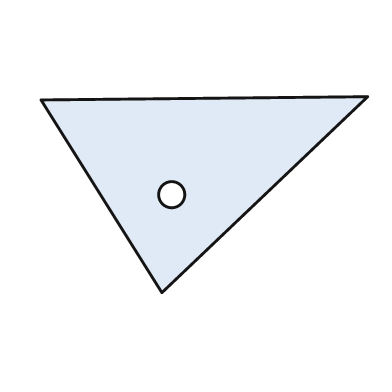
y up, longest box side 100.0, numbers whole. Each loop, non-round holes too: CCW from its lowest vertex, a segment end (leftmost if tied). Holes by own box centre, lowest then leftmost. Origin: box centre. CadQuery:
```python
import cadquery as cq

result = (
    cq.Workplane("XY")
    .moveTo(-13.0, -30.0)
    .lineTo(50.0, 30.0)
    .lineTo(-50.0, 29.0)
    .close()
    .moveTo(-10.0, 0.0)
    .circle(4.0)
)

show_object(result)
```